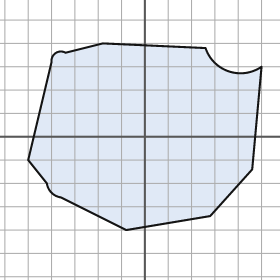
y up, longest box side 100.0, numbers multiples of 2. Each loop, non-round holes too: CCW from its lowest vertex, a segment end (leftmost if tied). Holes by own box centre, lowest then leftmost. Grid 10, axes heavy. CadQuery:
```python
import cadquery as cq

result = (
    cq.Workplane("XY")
    .moveTo(-8.0, -40.0)
    .lineTo(28.0, -34.0)
    .lineTo(46.0, -14.0)
    .lineTo(50.0, 30.0)
    .threePointArc((36.0, 28.0), (26.0, 38.0))
    .lineTo(-18.0, 40.0)
    .lineTo(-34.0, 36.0)
    .threePointArc((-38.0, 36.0), (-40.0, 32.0))
    .lineTo(-50.0, -10.0)
    .lineTo(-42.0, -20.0)
    .threePointArc((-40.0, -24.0), (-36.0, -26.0))
    .close()
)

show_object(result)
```